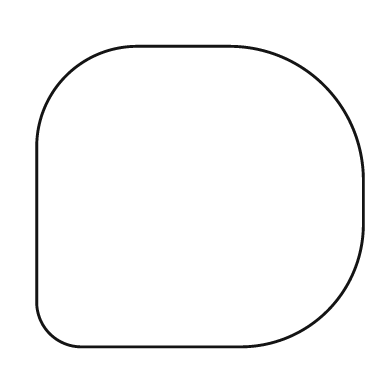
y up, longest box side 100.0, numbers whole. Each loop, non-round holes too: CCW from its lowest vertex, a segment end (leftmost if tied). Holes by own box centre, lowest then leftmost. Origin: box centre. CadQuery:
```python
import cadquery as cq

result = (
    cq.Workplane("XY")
    .moveTo(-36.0, -46.0)
    .lineTo(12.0, -46.0)
    .threePointArc((39.0, -35.0), (50.0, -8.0))
    .lineTo(50.0, 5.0)
    .threePointArc((38.0, 34.0), (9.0, 46.0))
    .lineTo(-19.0, 46.0)
    .threePointArc((-41.0, 37.0), (-50.0, 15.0))
    .lineTo(-50.0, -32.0)
    .threePointArc((-46.0, -42.0), (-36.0, -46.0))
    .close()
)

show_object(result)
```